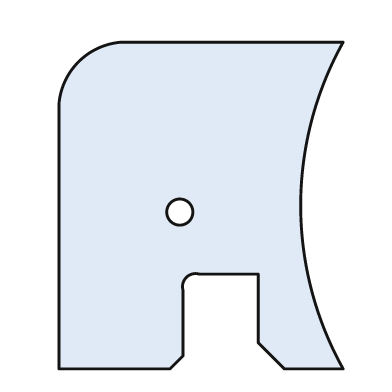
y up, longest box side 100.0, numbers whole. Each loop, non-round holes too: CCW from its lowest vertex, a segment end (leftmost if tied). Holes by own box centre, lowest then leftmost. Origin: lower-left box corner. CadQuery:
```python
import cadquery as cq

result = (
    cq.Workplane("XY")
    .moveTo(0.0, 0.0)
    .lineTo(34.0, 0.0)
    .lineTo(38.0, 4.0)
    .lineTo(38.0, 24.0)
    .threePointArc((39.0, 28.0), (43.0, 29.0))
    .lineTo(61.0, 29.0)
    .lineTo(61.0, 8.0)
    .lineTo(69.0, 0.0)
    .lineTo(87.0, 0.0)
    .threePointArc((74.0, 50.0), (87.0, 100.0))
    .lineTo(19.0, 100.0)
    .threePointArc((6.0, 94.0), (0.0, 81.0))
    .close()
    .moveTo(37.0, 48.0)
    .circle(4.0)
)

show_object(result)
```